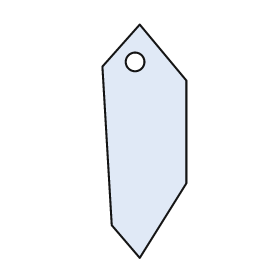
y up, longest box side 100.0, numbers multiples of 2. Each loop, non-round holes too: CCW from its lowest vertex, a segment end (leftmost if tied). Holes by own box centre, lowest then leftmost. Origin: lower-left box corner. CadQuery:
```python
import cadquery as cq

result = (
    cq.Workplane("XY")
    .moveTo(16.0, 0.0)
    .lineTo(36.0, 32.0)
    .lineTo(36.0, 76.0)
    .lineTo(16.0, 100.0)
    .lineTo(0.0, 82.0)
    .lineTo(4.0, 14.0)
    .close()
    .moveTo(14.0, 84.0)
    .circle(4.0)
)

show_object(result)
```